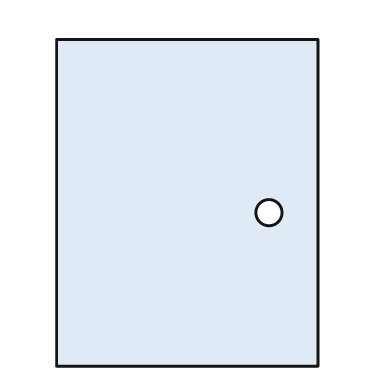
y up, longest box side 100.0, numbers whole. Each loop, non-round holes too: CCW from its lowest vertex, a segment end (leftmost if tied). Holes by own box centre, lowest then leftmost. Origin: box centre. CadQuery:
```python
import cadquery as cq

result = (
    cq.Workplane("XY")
    .moveTo(-40.0, -50.0)
    .lineTo(40.0, -50.0)
    .lineTo(40.0, 50.0)
    .lineTo(-40.0, 50.0)
    .close()
    .moveTo(25.0, -3.0)
    .circle(4.0)
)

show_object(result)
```